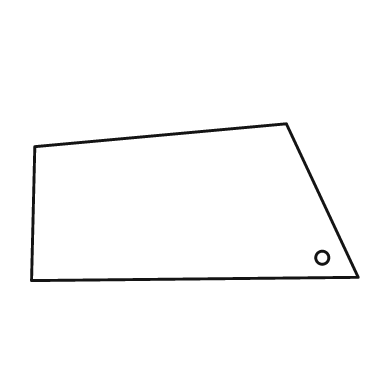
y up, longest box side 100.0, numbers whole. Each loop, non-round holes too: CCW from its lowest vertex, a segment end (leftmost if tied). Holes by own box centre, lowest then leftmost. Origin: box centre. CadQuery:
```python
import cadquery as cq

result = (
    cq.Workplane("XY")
    .moveTo(-50.0, -24.0)
    .lineTo(50.0, -23.0)
    .lineTo(28.0, 24.0)
    .lineTo(-49.0, 17.0)
    .close()
    .moveTo(39.0, -17.0)
    .circle(2.0)
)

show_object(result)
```